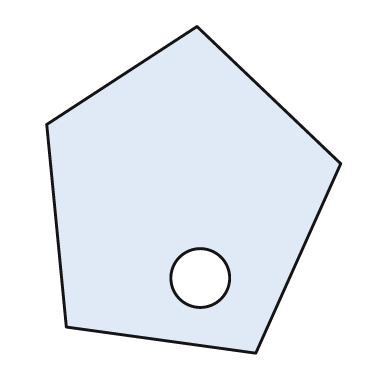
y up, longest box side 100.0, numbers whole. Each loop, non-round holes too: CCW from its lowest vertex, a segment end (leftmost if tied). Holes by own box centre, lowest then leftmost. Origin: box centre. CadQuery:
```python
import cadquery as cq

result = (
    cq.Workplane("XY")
    .moveTo(19.0, -50.0)
    .lineTo(45.0, 8.0)
    .lineTo(1.0, 50.0)
    .lineTo(-45.0, 20.0)
    .lineTo(-39.0, -42.0)
    .close()
    .moveTo(2.0, -27.0)
    .circle(9.0)
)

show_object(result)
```